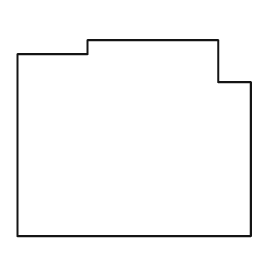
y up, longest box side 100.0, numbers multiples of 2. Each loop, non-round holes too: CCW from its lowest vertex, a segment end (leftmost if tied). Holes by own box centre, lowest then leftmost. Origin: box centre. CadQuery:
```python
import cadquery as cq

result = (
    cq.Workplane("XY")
    .moveTo(-50.0, -42.0)
    .lineTo(50.0, -42.0)
    .lineTo(50.0, 24.0)
    .lineTo(36.0, 24.0)
    .lineTo(36.0, 42.0)
    .lineTo(-20.0, 42.0)
    .lineTo(-20.0, 36.0)
    .lineTo(-50.0, 36.0)
    .close()
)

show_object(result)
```